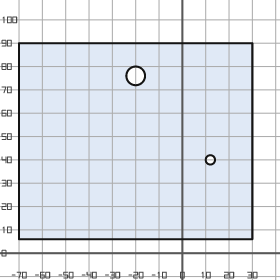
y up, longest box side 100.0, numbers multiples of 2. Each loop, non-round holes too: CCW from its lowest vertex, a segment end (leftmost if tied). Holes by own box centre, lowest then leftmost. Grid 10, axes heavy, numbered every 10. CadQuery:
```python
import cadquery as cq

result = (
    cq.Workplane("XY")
    .moveTo(-70.0, 6.0)
    .lineTo(30.0, 6.0)
    .lineTo(30.0, 90.0)
    .lineTo(-70.0, 90.0)
    .close()
    .moveTo(12.0, 40.0)
    .circle(2.0)
    .moveTo(-20.0, 76.0)
    .circle(4.0)
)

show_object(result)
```